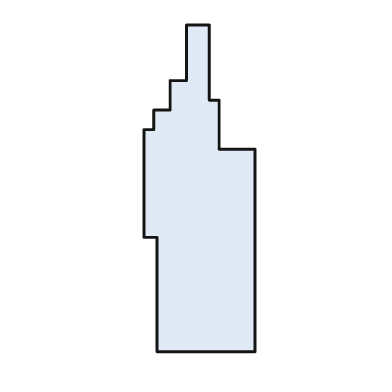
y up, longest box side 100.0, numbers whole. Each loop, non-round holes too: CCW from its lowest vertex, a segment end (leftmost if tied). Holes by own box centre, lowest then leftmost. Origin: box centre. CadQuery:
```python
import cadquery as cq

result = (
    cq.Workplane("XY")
    .moveTo(-13.0, -50.0)
    .lineTo(17.0, -50.0)
    .lineTo(17.0, 12.0)
    .lineTo(6.0, 12.0)
    .lineTo(6.0, 27.0)
    .lineTo(3.0, 27.0)
    .lineTo(3.0, 50.0)
    .lineTo(-4.0, 50.0)
    .lineTo(-4.0, 33.0)
    .lineTo(-9.0, 33.0)
    .lineTo(-9.0, 24.0)
    .lineTo(-14.0, 24.0)
    .lineTo(-14.0, 18.0)
    .lineTo(-17.0, 18.0)
    .lineTo(-17.0, -15.0)
    .lineTo(-13.0, -15.0)
    .close()
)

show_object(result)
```